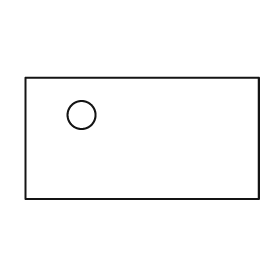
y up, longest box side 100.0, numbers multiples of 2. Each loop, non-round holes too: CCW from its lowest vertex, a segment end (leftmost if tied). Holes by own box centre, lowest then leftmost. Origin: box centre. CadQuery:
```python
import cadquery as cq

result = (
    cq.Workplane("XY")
    .moveTo(-50.0, -26.0)
    .lineTo(50.0, -26.0)
    .lineTo(50.0, 26.0)
    .lineTo(-50.0, 26.0)
    .close()
    .moveTo(-26.0, 10.0)
    .circle(6.0)
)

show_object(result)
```